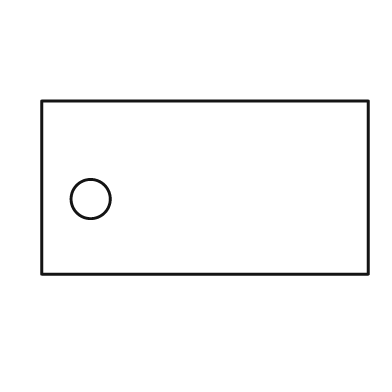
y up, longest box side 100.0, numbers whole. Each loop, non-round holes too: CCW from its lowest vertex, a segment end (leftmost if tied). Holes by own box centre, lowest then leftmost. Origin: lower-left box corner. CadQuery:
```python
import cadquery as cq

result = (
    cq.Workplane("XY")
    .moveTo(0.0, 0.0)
    .lineTo(100.0, 0.0)
    .lineTo(100.0, 53.0)
    .lineTo(0.0, 53.0)
    .close()
    .moveTo(15.0, 23.0)
    .circle(6.0)
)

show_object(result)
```